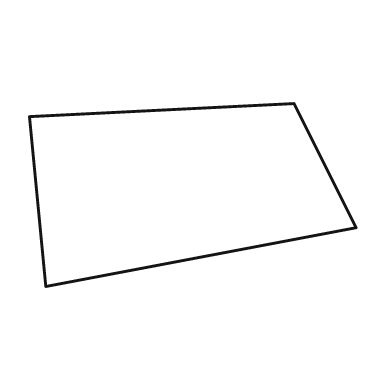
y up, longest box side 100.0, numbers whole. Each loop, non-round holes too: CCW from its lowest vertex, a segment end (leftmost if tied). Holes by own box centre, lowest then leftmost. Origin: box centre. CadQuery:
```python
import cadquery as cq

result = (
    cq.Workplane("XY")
    .moveTo(-45.0, -28.0)
    .lineTo(50.0, -10.0)
    .lineTo(31.0, 28.0)
    .lineTo(-50.0, 24.0)
    .close()
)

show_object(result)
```